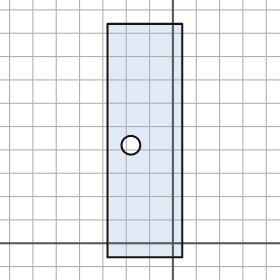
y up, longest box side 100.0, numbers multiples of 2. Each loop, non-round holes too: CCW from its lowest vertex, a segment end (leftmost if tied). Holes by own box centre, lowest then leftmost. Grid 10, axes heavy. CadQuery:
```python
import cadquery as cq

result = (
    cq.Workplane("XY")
    .moveTo(-28.0, -6.0)
    .lineTo(4.0, -6.0)
    .lineTo(4.0, 94.0)
    .lineTo(-28.0, 94.0)
    .close()
    .moveTo(-18.0, 42.0)
    .circle(4.0)
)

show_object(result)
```